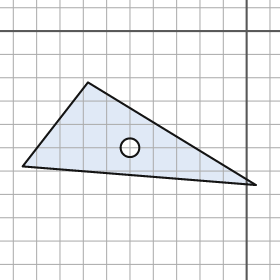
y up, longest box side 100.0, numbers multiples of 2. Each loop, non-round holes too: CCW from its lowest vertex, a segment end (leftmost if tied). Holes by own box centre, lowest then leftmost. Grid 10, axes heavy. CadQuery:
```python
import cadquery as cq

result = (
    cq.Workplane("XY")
    .moveTo(4.0, -66.0)
    .lineTo(-68.0, -22.0)
    .lineTo(-96.0, -58.0)
    .close()
    .moveTo(-50.0, -50.0)
    .circle(4.0)
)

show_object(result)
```